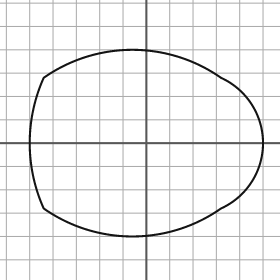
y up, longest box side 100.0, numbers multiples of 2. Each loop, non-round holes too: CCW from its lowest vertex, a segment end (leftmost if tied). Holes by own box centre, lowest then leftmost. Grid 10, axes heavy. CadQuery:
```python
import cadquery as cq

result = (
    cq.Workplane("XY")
    .moveTo(-44.0, -28.0)
    .threePointArc((-6.0, -40.0), (32.0, -28.0))
    .threePointArc((50.0, 0.0), (32.0, 28.0))
    .threePointArc((-6.0, 40.0), (-44.0, 28.0))
    .threePointArc((-50.0, 0.0), (-44.0, -28.0))
    .close()
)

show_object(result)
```